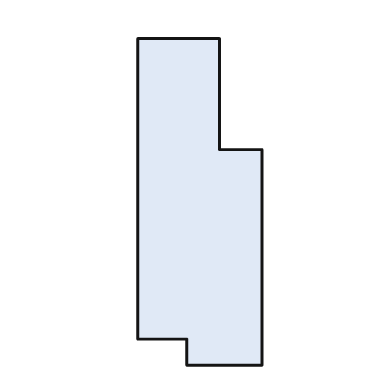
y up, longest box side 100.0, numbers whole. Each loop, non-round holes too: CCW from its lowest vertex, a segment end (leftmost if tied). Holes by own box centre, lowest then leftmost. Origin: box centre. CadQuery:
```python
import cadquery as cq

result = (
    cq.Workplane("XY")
    .moveTo(-4.0, -50.0)
    .lineTo(19.0, -50.0)
    .lineTo(19.0, 16.0)
    .lineTo(6.0, 16.0)
    .lineTo(6.0, 50.0)
    .lineTo(-19.0, 50.0)
    .lineTo(-19.0, -42.0)
    .lineTo(-4.0, -42.0)
    .close()
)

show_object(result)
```